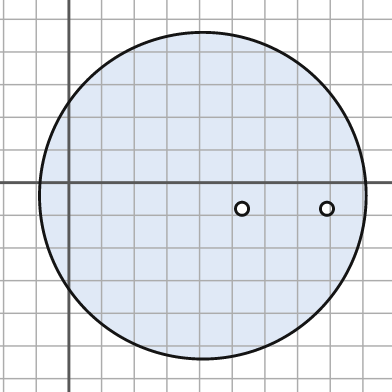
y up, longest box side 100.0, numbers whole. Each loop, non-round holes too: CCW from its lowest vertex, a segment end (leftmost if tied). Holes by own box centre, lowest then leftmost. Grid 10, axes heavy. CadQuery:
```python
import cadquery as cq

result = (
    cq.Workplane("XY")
    .moveTo(41.0, -4.0)
    .circle(50.0)
    .moveTo(53.0, -8.0)
    .circle(2.0)
    .moveTo(79.0, -8.0)
    .circle(2.0)
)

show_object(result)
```